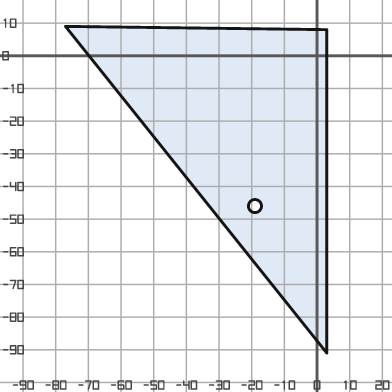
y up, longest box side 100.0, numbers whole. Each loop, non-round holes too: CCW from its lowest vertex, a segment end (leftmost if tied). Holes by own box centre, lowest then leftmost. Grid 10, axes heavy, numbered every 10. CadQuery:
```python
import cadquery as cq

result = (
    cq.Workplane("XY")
    .moveTo(3.0, -91.0)
    .lineTo(3.0, 8.0)
    .lineTo(-77.0, 9.0)
    .close()
    .moveTo(-19.0, -46.0)
    .circle(2.0)
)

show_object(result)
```